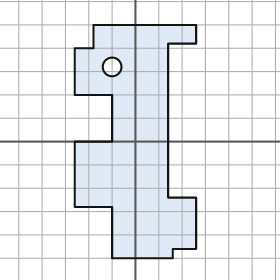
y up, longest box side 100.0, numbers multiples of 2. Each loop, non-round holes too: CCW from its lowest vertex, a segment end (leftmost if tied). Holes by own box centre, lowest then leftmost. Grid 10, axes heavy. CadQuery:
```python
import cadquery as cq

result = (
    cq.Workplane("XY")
    .moveTo(-10.0, -50.0)
    .lineTo(16.0, -50.0)
    .lineTo(16.0, -46.0)
    .lineTo(26.0, -46.0)
    .lineTo(26.0, -24.0)
    .lineTo(14.0, -24.0)
    .lineTo(14.0, 42.0)
    .lineTo(26.0, 42.0)
    .lineTo(26.0, 50.0)
    .lineTo(-18.0, 50.0)
    .lineTo(-18.0, 40.0)
    .lineTo(-26.0, 40.0)
    .lineTo(-26.0, 20.0)
    .lineTo(-10.0, 20.0)
    .lineTo(-10.0, 0.0)
    .lineTo(-26.0, 0.0)
    .lineTo(-26.0, -28.0)
    .lineTo(-10.0, -28.0)
    .close()
    .moveTo(-10.0, 32.0)
    .circle(4.0)
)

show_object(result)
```